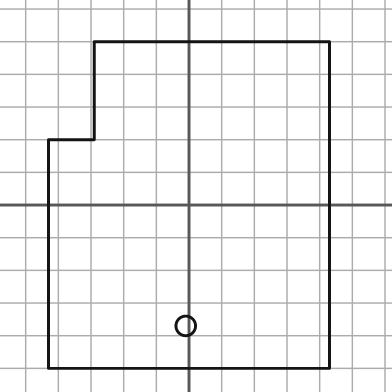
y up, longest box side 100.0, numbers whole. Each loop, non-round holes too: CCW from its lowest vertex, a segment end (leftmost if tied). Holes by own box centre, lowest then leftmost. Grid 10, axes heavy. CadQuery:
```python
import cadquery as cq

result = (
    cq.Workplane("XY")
    .moveTo(-43.0, -50.0)
    .lineTo(43.0, -50.0)
    .lineTo(43.0, 50.0)
    .lineTo(-29.0, 50.0)
    .lineTo(-29.0, 20.0)
    .lineTo(-43.0, 20.0)
    .close()
    .moveTo(-1.0, -37.0)
    .circle(3.0)
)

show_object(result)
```